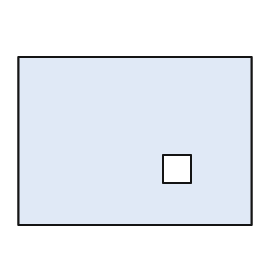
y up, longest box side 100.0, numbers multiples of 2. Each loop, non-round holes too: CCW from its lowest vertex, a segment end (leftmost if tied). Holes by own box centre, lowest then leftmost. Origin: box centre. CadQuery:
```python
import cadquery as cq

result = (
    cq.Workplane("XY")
    .moveTo(-50.0, -36.0)
    .lineTo(50.0, -36.0)
    .lineTo(50.0, 36.0)
    .lineTo(-50.0, 36.0)
    .close()
    .moveTo(12.0, -18.0)
    .lineTo(24.0, -18.0)
    .lineTo(24.0, -6.0)
    .lineTo(12.0, -6.0)
    .close()
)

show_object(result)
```